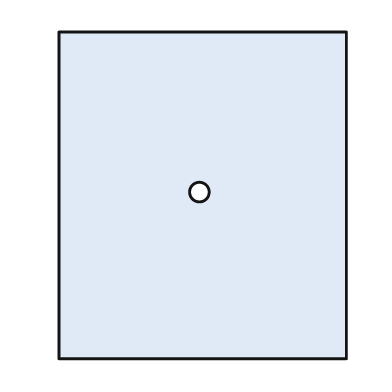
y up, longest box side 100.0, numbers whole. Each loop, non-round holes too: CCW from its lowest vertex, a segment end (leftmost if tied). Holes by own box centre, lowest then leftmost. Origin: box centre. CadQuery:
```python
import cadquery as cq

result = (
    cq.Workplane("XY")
    .moveTo(-44.0, -50.0)
    .lineTo(44.0, -50.0)
    .lineTo(44.0, 50.0)
    .lineTo(-44.0, 50.0)
    .close()
    .moveTo(-1.0, 1.0)
    .circle(3.0)
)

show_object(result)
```